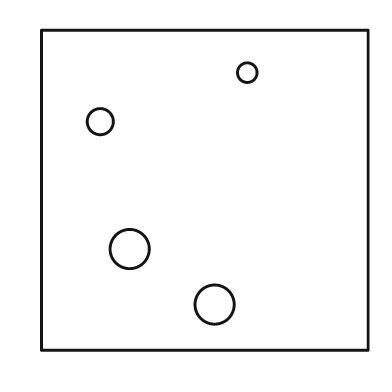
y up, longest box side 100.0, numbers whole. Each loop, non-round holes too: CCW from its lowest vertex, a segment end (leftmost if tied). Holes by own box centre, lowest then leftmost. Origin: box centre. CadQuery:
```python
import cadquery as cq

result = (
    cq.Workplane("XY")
    .moveTo(-50.0, -49.0)
    .lineTo(50.0, -49.0)
    .lineTo(50.0, 49.0)
    .lineTo(-50.0, 49.0)
    .close()
    .moveTo(3.0, -35.0)
    .circle(6.0)
    .moveTo(-23.0, -18.0)
    .circle(6.0)
    .moveTo(-32.0, 21.0)
    .circle(4.0)
    .moveTo(13.0, 36.0)
    .circle(3.0)
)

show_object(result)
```